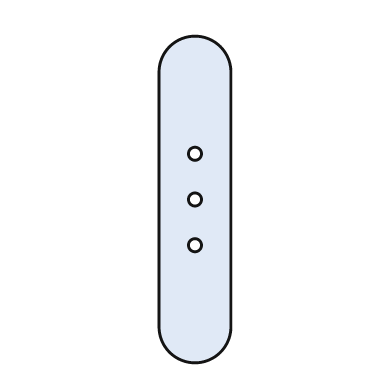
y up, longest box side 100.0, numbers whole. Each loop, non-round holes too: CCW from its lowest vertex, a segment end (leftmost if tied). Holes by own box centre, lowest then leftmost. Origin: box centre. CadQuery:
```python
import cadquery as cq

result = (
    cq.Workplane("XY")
    .moveTo(-11.0, -39.0)
    .threePointArc((0.0, -50.0), (11.0, -39.0))
    .lineTo(11.0, 39.0)
    .threePointArc((0.0, 50.0), (-11.0, 39.0))
    .close()
    .moveTo(0.0, -14.0)
    .circle(2.0)
    .moveTo(0.0, 0.0)
    .circle(2.0)
    .moveTo(0.0, 14.0)
    .circle(2.0)
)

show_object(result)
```